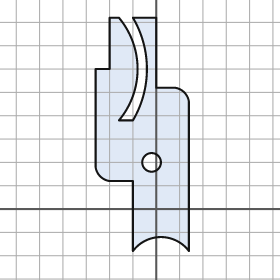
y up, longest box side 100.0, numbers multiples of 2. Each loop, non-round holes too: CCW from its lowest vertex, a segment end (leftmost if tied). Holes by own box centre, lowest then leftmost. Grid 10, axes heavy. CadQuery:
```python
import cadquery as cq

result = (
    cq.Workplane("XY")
    .moveTo(-10.0, -18.0)
    .threePointArc((2.0, -12.0), (14.0, -18.0))
    .lineTo(14.0, 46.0)
    .threePointArc((12.0, 50.0), (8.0, 52.0))
    .lineTo(0.0, 52.0)
    .lineTo(0.0, 82.0)
    .lineTo(-10.0, 82.0)
    .threePointArc((-4.0, 60.0), (-10.0, 38.0))
    .lineTo(-16.0, 38.0)
    .threePointArc((-8.0, 60.0), (-16.0, 82.0))
    .lineTo(-20.0, 82.0)
    .lineTo(-20.0, 60.0)
    .lineTo(-26.0, 60.0)
    .lineTo(-26.0, 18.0)
    .threePointArc((-24.0, 14.0), (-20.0, 12.0))
    .lineTo(-10.0, 12.0)
    .close()
    .moveTo(-2.0, 20.0)
    .circle(4.0)
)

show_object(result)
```